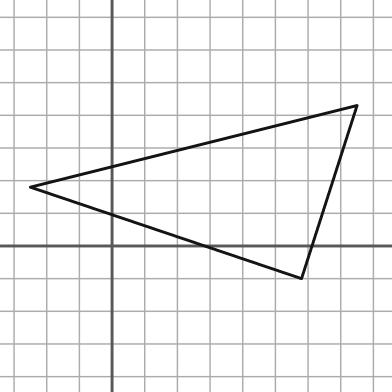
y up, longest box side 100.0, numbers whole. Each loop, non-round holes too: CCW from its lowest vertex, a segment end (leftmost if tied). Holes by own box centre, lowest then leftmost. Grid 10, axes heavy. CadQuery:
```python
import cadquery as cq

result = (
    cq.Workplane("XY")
    .moveTo(58.0, -10.0)
    .lineTo(75.0, 43.0)
    .lineTo(-25.0, 18.0)
    .close()
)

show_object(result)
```